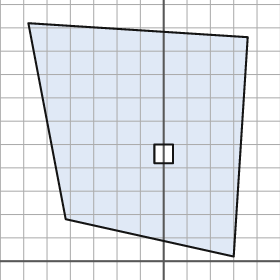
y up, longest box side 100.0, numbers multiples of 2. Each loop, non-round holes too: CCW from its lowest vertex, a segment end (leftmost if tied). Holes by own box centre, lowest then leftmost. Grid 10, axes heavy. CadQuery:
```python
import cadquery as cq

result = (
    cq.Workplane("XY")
    .moveTo(30.0, 2.0)
    .lineTo(36.0, 96.0)
    .lineTo(-58.0, 102.0)
    .lineTo(-42.0, 18.0)
    .close()
    .moveTo(-4.0, 42.0)
    .lineTo(4.0, 42.0)
    .lineTo(4.0, 50.0)
    .lineTo(-4.0, 50.0)
    .close()
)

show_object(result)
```